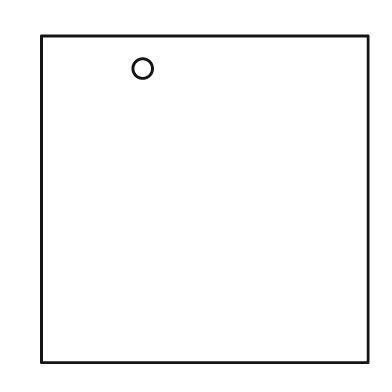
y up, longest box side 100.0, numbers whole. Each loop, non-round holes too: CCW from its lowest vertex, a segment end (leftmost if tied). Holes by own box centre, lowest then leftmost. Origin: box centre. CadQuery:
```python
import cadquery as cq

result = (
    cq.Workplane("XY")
    .moveTo(-50.0, -50.0)
    .lineTo(50.0, -50.0)
    .lineTo(50.0, 50.0)
    .lineTo(-50.0, 50.0)
    .close()
    .moveTo(-19.0, 40.0)
    .circle(3.0)
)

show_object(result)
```